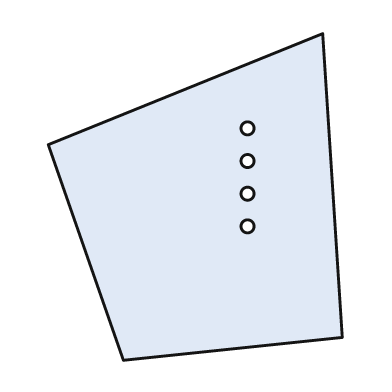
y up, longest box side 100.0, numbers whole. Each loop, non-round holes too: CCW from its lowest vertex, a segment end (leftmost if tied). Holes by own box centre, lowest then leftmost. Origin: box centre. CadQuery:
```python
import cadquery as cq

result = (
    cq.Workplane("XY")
    .moveTo(-22.0, -50.0)
    .lineTo(45.0, -43.0)
    .lineTo(39.0, 50.0)
    .lineTo(-45.0, 16.0)
    .close()
    .moveTo(16.0, -9.0)
    .circle(2.0)
    .moveTo(16.0, 1.0)
    .circle(2.0)
    .moveTo(16.0, 11.0)
    .circle(2.0)
    .moveTo(16.0, 21.0)
    .circle(2.0)
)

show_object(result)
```